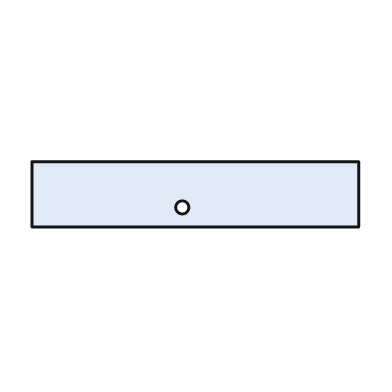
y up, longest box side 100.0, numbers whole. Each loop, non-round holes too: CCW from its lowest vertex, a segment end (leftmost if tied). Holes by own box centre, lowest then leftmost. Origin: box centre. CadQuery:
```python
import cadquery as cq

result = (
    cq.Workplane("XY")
    .moveTo(-50.0, -10.0)
    .lineTo(50.0, -10.0)
    .lineTo(50.0, 10.0)
    .lineTo(-50.0, 10.0)
    .close()
    .moveTo(-4.0, -4.0)
    .circle(2.0)
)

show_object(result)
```